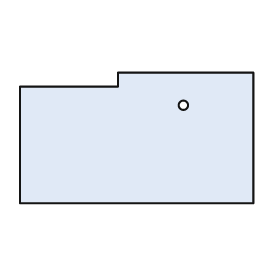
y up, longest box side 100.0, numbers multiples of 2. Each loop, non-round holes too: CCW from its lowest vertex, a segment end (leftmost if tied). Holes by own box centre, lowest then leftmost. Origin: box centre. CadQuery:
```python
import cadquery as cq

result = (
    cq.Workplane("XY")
    .moveTo(-50.0, -28.0)
    .lineTo(50.0, -28.0)
    .lineTo(50.0, 28.0)
    .lineTo(-8.0, 28.0)
    .lineTo(-8.0, 22.0)
    .lineTo(-50.0, 22.0)
    .close()
    .moveTo(20.0, 14.0)
    .circle(2.0)
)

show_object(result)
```